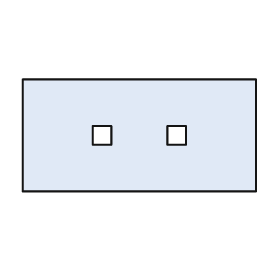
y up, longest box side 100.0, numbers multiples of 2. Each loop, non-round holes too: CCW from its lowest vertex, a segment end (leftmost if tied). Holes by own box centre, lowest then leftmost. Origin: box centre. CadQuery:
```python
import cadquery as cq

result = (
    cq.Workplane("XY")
    .moveTo(-50.0, -24.0)
    .lineTo(50.0, -24.0)
    .lineTo(50.0, 24.0)
    .lineTo(-50.0, 24.0)
    .close()
    .moveTo(-20.0, -4.0)
    .lineTo(-12.0, -4.0)
    .lineTo(-12.0, 4.0)
    .lineTo(-20.0, 4.0)
    .close()
    .moveTo(12.0, -4.0)
    .lineTo(20.0, -4.0)
    .lineTo(20.0, 4.0)
    .lineTo(12.0, 4.0)
    .close()
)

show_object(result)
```